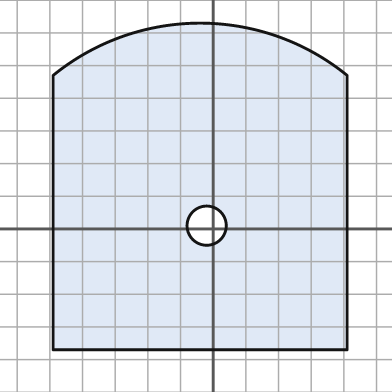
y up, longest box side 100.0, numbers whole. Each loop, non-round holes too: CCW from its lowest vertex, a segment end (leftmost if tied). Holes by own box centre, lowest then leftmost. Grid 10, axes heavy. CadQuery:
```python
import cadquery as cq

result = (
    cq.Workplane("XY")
    .moveTo(-49.0, -37.0)
    .lineTo(41.0, -37.0)
    .lineTo(41.0, 47.0)
    .threePointArc((-4.0, 63.0), (-49.0, 47.0))
    .close()
    .moveTo(-2.0, 1.0)
    .circle(6.0)
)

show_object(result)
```